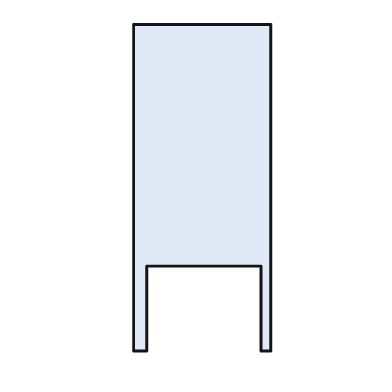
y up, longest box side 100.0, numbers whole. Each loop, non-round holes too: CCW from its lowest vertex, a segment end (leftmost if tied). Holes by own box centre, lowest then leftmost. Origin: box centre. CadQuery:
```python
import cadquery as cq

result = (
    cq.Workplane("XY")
    .moveTo(-21.0, -50.0)
    .lineTo(-17.0, -50.0)
    .lineTo(-17.0, -24.0)
    .lineTo(18.0, -24.0)
    .lineTo(18.0, -50.0)
    .lineTo(21.0, -50.0)
    .lineTo(21.0, 50.0)
    .lineTo(-21.0, 50.0)
    .close()
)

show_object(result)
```